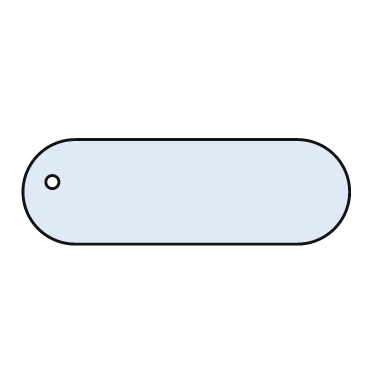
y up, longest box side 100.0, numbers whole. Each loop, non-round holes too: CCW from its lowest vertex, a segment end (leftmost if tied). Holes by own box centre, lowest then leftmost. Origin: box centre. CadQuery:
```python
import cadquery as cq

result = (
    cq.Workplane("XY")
    .moveTo(-34.0, -16.0)
    .lineTo(34.0, -16.0)
    .threePointArc((50.0, 0.0), (34.0, 16.0))
    .lineTo(-34.0, 16.0)
    .threePointArc((-50.0, 0.0), (-34.0, -16.0))
    .close()
    .moveTo(-41.0, 3.0)
    .circle(2.0)
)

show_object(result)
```